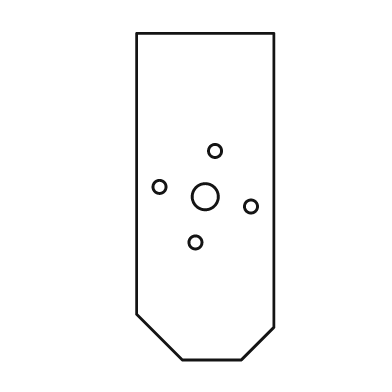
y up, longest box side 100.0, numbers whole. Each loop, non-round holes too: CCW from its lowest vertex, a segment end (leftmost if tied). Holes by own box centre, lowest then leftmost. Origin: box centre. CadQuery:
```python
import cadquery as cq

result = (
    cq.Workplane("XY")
    .moveTo(-7.0, -50.0)
    .lineTo(11.0, -50.0)
    .lineTo(21.0, -40.0)
    .lineTo(21.0, 50.0)
    .lineTo(-21.0, 50.0)
    .lineTo(-21.0, -36.0)
    .close()
    .moveTo(-3.0, -14.0)
    .circle(2.0)
    .moveTo(14.0, -3.0)
    .circle(2.0)
    .moveTo(0.0, 0.0)
    .circle(4.0)
    .moveTo(-14.0, 3.0)
    .circle(2.0)
    .moveTo(3.0, 14.0)
    .circle(2.0)
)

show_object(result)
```